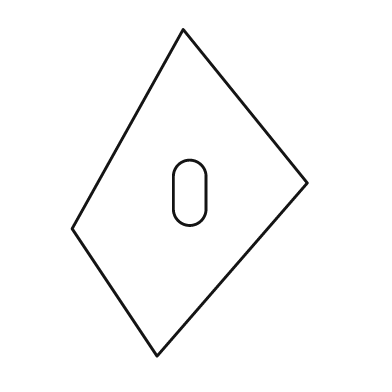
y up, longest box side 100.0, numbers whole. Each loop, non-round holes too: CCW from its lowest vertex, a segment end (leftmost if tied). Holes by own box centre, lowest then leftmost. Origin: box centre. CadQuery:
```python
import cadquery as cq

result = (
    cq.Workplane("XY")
    .moveTo(-10.0, -50.0)
    .lineTo(36.0, 3.0)
    .lineTo(-2.0, 50.0)
    .lineTo(-36.0, -11.0)
    .close()
    .moveTo(-5.0, -5.0)
    .threePointArc((0.0, -10.0), (5.0, -5.0))
    .lineTo(5.0, 5.0)
    .threePointArc((0.0, 10.0), (-5.0, 5.0))
    .close()
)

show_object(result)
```